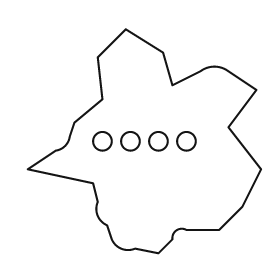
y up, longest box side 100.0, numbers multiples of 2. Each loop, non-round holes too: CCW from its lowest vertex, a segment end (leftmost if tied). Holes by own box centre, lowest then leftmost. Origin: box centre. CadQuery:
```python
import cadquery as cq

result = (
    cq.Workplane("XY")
    .moveTo(6.0, -48.0)
    .lineTo(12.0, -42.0)
    .threePointArc((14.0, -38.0), (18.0, -38.0))
    .lineTo(32.0, -38.0)
    .lineTo(42.0, -28.0)
    .lineTo(50.0, -12.0)
    .lineTo(36.0, 6.0)
    .lineTo(48.0, 22.0)
    .lineTo(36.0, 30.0)
    .threePointArc((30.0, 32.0), (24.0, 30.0))
    .lineTo(12.0, 24.0)
    .lineTo(8.0, 38.0)
    .lineTo(-8.0, 48.0)
    .lineTo(-20.0, 36.0)
    .lineTo(-18.0, 18.0)
    .lineTo(-30.0, 8.0)
    .lineTo(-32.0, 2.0)
    .threePointArc((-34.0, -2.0), (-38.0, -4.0))
    .lineTo(-50.0, -12.0)
    .lineTo(-22.0, -18.0)
    .lineTo(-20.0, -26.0)
    .threePointArc((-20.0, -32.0), (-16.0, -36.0))
    .lineTo(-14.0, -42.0)
    .threePointArc((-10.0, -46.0), (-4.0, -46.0))
    .close()
    .moveTo(-18.0, 0.0)
    .circle(4.0)
    .moveTo(-6.0, 0.0)
    .circle(4.0)
    .moveTo(6.0, 0.0)
    .circle(4.0)
    .moveTo(18.0, 0.0)
    .circle(4.0)
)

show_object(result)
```